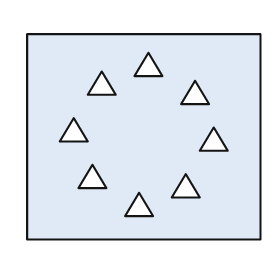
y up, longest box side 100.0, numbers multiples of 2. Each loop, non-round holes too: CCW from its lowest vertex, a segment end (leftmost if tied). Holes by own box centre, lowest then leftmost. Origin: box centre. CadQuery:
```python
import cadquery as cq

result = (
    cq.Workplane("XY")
    .moveTo(-50.0, -44.0)
    .lineTo(50.0, -44.0)
    .lineTo(50.0, 44.0)
    .lineTo(-50.0, 44.0)
    .close()
    .moveTo(-8.0, -34.0)
    .lineTo(4.0, -34.0)
    .lineTo(-2.0, -24.0)
    .close()
    .moveTo(12.0, -26.0)
    .lineTo(24.0, -26.0)
    .lineTo(18.0, -16.0)
    .close()
    .moveTo(-28.0, -22.0)
    .lineTo(-16.0, -22.0)
    .lineTo(-22.0, -12.0)
    .close()
    .moveTo(24.0, -6.0)
    .lineTo(36.0, -6.0)
    .lineTo(30.0, 4.0)
    .close()
    .moveTo(-36.0, -2.0)
    .lineTo(-24.0, -2.0)
    .lineTo(-30.0, 8.0)
    .close()
    .moveTo(16.0, 14.0)
    .lineTo(28.0, 14.0)
    .lineTo(22.0, 24.0)
    .close()
    .moveTo(-24.0, 18.0)
    .lineTo(-12.0, 18.0)
    .lineTo(-18.0, 28.0)
    .close()
    .moveTo(-4.0, 26.0)
    .lineTo(8.0, 26.0)
    .lineTo(2.0, 36.0)
    .close()
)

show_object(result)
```